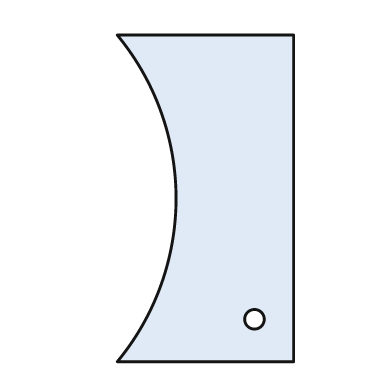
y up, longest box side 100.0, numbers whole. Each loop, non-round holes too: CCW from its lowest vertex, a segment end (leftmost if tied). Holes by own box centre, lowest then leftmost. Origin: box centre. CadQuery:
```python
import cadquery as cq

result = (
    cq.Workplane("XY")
    .moveTo(-27.0, -50.0)
    .lineTo(27.0, -50.0)
    .lineTo(27.0, 50.0)
    .lineTo(-27.0, 50.0)
    .threePointArc((-9.0, 0.0), (-27.0, -50.0))
    .close()
    .moveTo(15.0, -37.0)
    .circle(3.0)
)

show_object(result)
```